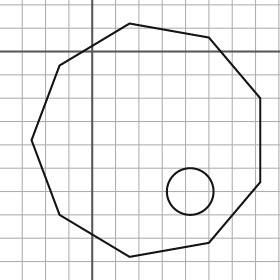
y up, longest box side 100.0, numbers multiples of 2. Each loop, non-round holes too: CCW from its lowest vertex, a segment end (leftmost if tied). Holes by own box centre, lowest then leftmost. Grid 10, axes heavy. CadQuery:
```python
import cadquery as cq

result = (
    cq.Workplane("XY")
    .moveTo(16.0, -88.0)
    .lineTo(50.0, -82.0)
    .lineTo(72.0, -56.0)
    .lineTo(72.0, -20.0)
    .lineTo(50.0, 6.0)
    .lineTo(16.0, 12.0)
    .lineTo(-14.0, -6.0)
    .lineTo(-26.0, -38.0)
    .lineTo(-14.0, -70.0)
    .close()
    .moveTo(42.0, -60.0)
    .circle(10.0)
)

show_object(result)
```